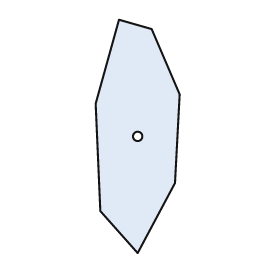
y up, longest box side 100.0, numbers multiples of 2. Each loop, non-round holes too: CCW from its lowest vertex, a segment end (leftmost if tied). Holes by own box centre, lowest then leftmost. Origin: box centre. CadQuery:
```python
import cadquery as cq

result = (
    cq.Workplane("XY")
    .moveTo(0.0, -50.0)
    .lineTo(16.0, -20.0)
    .lineTo(18.0, 18.0)
    .lineTo(6.0, 46.0)
    .lineTo(-8.0, 50.0)
    .lineTo(-18.0, 14.0)
    .lineTo(-16.0, -32.0)
    .close()
    .moveTo(0.0, 0.0)
    .circle(2.0)
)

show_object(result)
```